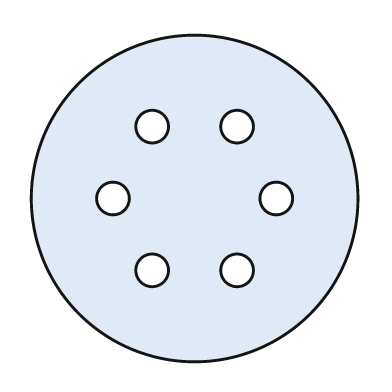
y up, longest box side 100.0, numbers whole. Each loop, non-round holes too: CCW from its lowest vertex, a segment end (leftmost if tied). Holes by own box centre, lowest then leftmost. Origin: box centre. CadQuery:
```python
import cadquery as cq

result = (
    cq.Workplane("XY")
    .moveTo(0.0, 0.0)
    .circle(50.0)
    .moveTo(-13.0, -22.0)
    .circle(5.0)
    .moveTo(13.0, -22.0)
    .circle(5.0)
    .moveTo(-25.0, 0.0)
    .circle(5.0)
    .moveTo(25.0, 0.0)
    .circle(5.0)
    .moveTo(-13.0, 22.0)
    .circle(5.0)
    .moveTo(13.0, 22.0)
    .circle(5.0)
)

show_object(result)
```